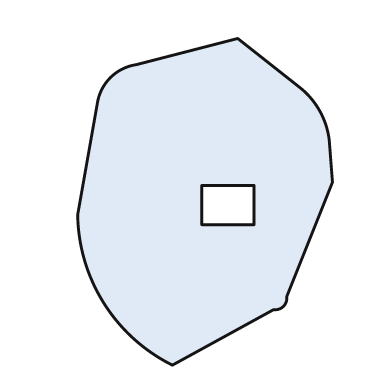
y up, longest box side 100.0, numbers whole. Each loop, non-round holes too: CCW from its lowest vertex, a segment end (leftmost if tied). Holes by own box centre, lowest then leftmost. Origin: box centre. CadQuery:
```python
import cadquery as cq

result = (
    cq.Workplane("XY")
    .moveTo(-10.0, -50.0)
    .lineTo(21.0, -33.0)
    .threePointArc((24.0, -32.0), (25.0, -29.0))
    .lineTo(39.0, 6.0)
    .lineTo(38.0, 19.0)
    .threePointArc((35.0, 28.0), (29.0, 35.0))
    .lineTo(10.0, 50.0)
    .lineTo(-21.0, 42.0)
    .threePointArc((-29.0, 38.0), (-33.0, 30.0))
    .lineTo(-39.0, -4.0)
    .threePointArc((-31.0, -31.0), (-10.0, -50.0))
    .close()
    .moveTo(-1.0, -7.0)
    .lineTo(15.0, -7.0)
    .lineTo(15.0, 5.0)
    .lineTo(-1.0, 5.0)
    .close()
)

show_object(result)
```